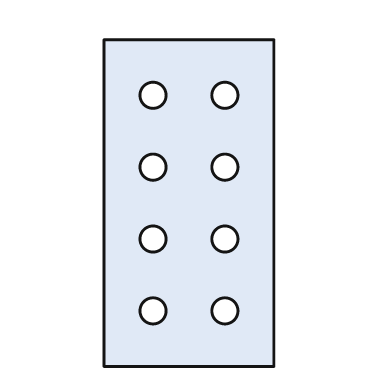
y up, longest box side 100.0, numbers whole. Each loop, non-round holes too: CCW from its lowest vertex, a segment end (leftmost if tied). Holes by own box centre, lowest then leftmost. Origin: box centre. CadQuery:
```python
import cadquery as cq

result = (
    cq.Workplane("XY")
    .moveTo(-26.0, -50.0)
    .lineTo(26.0, -50.0)
    .lineTo(26.0, 50.0)
    .lineTo(-26.0, 50.0)
    .close()
    .moveTo(-11.0, -33.0)
    .circle(4.0)
    .moveTo(11.0, -33.0)
    .circle(4.0)
    .moveTo(-11.0, -11.0)
    .circle(4.0)
    .moveTo(11.0, -11.0)
    .circle(4.0)
    .moveTo(-11.0, 11.0)
    .circle(4.0)
    .moveTo(11.0, 11.0)
    .circle(4.0)
    .moveTo(-11.0, 33.0)
    .circle(4.0)
    .moveTo(11.0, 33.0)
    .circle(4.0)
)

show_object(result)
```